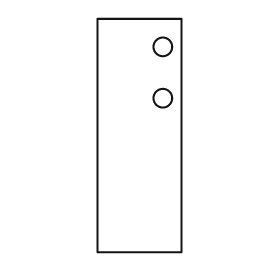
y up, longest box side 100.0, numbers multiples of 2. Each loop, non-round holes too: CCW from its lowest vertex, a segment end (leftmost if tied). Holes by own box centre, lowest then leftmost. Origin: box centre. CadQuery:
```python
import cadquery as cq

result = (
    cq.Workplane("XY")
    .moveTo(-18.0, -50.0)
    .lineTo(18.0, -50.0)
    .lineTo(18.0, 50.0)
    .lineTo(-18.0, 50.0)
    .close()
    .moveTo(10.0, 16.0)
    .circle(4.0)
    .moveTo(10.0, 38.0)
    .circle(4.0)
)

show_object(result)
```